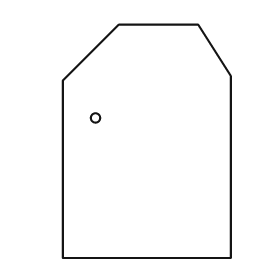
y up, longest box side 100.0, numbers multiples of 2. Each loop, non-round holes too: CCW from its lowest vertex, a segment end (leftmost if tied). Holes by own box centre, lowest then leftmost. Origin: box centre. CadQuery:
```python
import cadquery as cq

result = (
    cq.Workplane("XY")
    .moveTo(-36.0, -50.0)
    .lineTo(36.0, -50.0)
    .lineTo(36.0, 28.0)
    .lineTo(22.0, 50.0)
    .lineTo(-12.0, 50.0)
    .lineTo(-36.0, 26.0)
    .close()
    .moveTo(-22.0, 10.0)
    .circle(2.0)
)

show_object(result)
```